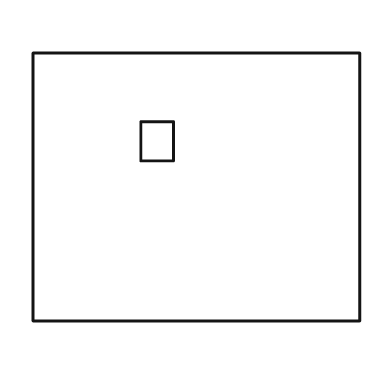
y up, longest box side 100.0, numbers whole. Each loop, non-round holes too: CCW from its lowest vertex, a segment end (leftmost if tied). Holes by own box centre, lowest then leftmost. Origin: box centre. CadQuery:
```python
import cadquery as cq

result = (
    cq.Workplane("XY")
    .moveTo(-50.0, -41.0)
    .lineTo(50.0, -41.0)
    .lineTo(50.0, 41.0)
    .lineTo(-50.0, 41.0)
    .close()
    .moveTo(-17.0, 8.0)
    .lineTo(-7.0, 8.0)
    .lineTo(-7.0, 20.0)
    .lineTo(-17.0, 20.0)
    .close()
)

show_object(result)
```